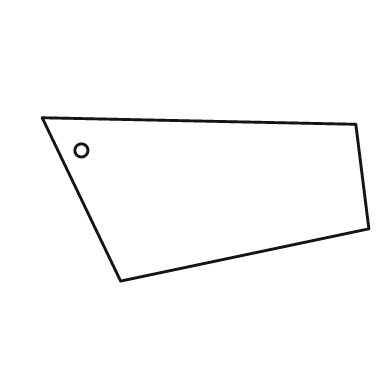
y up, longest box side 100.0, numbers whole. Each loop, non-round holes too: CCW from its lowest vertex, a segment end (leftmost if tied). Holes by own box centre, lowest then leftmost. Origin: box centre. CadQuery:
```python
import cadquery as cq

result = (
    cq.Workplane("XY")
    .moveTo(-26.0, -25.0)
    .lineTo(50.0, -9.0)
    .lineTo(46.0, 23.0)
    .lineTo(-50.0, 25.0)
    .close()
    .moveTo(-38.0, 15.0)
    .circle(2.0)
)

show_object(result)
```